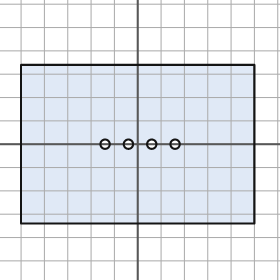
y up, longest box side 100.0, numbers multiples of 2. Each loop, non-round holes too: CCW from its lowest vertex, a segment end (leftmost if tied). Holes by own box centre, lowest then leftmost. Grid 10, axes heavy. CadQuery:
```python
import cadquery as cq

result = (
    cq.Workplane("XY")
    .moveTo(-50.0, -34.0)
    .lineTo(50.0, -34.0)
    .lineTo(50.0, 34.0)
    .lineTo(-50.0, 34.0)
    .close()
    .moveTo(-14.0, 0.0)
    .circle(2.0)
    .moveTo(-4.0, 0.0)
    .circle(2.0)
    .moveTo(6.0, 0.0)
    .circle(2.0)
    .moveTo(16.0, 0.0)
    .circle(2.0)
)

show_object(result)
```